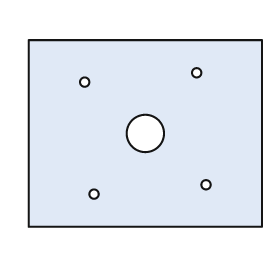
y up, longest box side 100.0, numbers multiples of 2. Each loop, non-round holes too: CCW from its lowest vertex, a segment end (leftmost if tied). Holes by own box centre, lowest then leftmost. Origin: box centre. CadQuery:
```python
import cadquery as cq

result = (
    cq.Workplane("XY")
    .moveTo(-50.0, -40.0)
    .lineTo(50.0, -40.0)
    .lineTo(50.0, 40.0)
    .lineTo(-50.0, 40.0)
    .close()
    .moveTo(-22.0, -26.0)
    .circle(2.0)
    .moveTo(26.0, -22.0)
    .circle(2.0)
    .moveTo(0.0, 0.0)
    .circle(8.0)
    .moveTo(-26.0, 22.0)
    .circle(2.0)
    .moveTo(22.0, 26.0)
    .circle(2.0)
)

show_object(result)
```